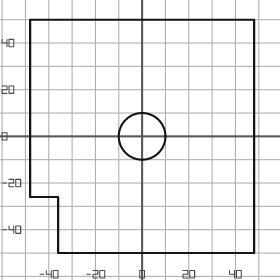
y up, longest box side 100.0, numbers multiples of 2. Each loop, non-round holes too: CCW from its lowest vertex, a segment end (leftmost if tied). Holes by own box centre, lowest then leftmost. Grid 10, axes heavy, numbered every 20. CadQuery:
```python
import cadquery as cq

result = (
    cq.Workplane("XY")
    .moveTo(-36.0, -50.0)
    .lineTo(48.0, -50.0)
    .lineTo(48.0, 50.0)
    .lineTo(-48.0, 50.0)
    .lineTo(-48.0, -26.0)
    .lineTo(-36.0, -26.0)
    .close()
    .moveTo(0.0, 0.0)
    .circle(10.0)
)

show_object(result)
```